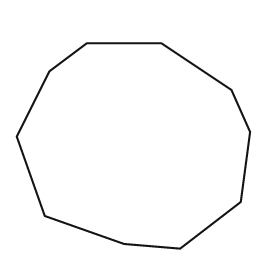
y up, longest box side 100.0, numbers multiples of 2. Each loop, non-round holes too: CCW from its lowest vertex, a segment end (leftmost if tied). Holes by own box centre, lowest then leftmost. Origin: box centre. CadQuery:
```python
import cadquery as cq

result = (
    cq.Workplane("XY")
    .moveTo(20.0, -44.0)
    .lineTo(46.0, -24.0)
    .lineTo(50.0, 6.0)
    .lineTo(42.0, 24.0)
    .lineTo(12.0, 44.0)
    .lineTo(-20.0, 44.0)
    .lineTo(-36.0, 32.0)
    .lineTo(-50.0, 4.0)
    .lineTo(-38.0, -30.0)
    .lineTo(-4.0, -42.0)
    .close()
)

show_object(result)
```